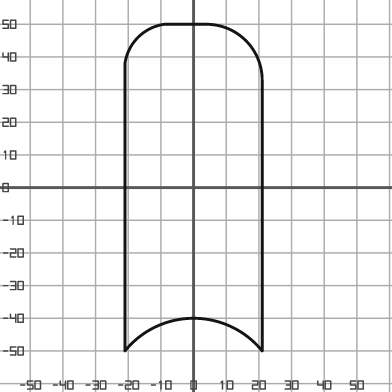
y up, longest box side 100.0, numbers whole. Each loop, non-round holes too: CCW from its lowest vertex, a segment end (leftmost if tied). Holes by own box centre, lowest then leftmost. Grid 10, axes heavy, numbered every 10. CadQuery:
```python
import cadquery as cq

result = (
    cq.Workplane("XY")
    .moveTo(-21.0, -50.0)
    .threePointArc((0.0, -40.0), (21.0, -50.0))
    .lineTo(21.0, 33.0)
    .threePointArc((16.0, 45.0), (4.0, 50.0))
    .lineTo(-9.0, 50.0)
    .threePointArc((-17.0, 46.0), (-21.0, 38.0))
    .close()
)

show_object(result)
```